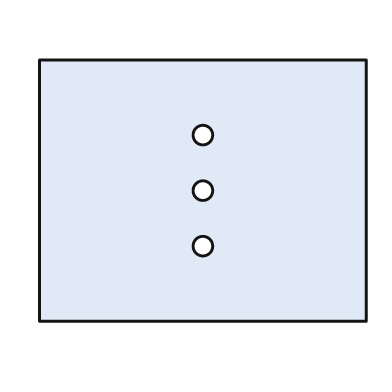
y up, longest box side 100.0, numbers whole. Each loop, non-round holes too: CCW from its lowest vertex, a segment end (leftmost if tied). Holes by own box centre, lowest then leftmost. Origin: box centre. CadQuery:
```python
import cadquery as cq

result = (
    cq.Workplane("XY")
    .moveTo(-50.0, -40.0)
    .lineTo(50.0, -40.0)
    .lineTo(50.0, 40.0)
    .lineTo(-50.0, 40.0)
    .close()
    .moveTo(0.0, -17.0)
    .circle(3.0)
    .moveTo(0.0, 0.0)
    .circle(3.0)
    .moveTo(0.0, 17.0)
    .circle(3.0)
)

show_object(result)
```